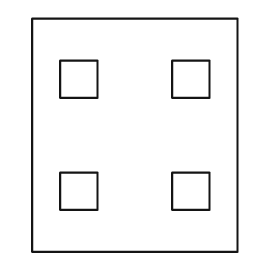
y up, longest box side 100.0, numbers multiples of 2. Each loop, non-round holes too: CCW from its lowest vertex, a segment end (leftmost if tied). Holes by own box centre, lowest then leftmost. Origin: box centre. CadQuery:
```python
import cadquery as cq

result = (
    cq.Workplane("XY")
    .moveTo(-44.0, -50.0)
    .lineTo(44.0, -50.0)
    .lineTo(44.0, 50.0)
    .lineTo(-44.0, 50.0)
    .close()
    .moveTo(-32.0, -32.0)
    .lineTo(-16.0, -32.0)
    .lineTo(-16.0, -16.0)
    .lineTo(-32.0, -16.0)
    .close()
    .moveTo(16.0, -32.0)
    .lineTo(32.0, -32.0)
    .lineTo(32.0, -16.0)
    .lineTo(16.0, -16.0)
    .close()
    .moveTo(-32.0, 16.0)
    .lineTo(-16.0, 16.0)
    .lineTo(-16.0, 32.0)
    .lineTo(-32.0, 32.0)
    .close()
    .moveTo(16.0, 16.0)
    .lineTo(32.0, 16.0)
    .lineTo(32.0, 32.0)
    .lineTo(16.0, 32.0)
    .close()
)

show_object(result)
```